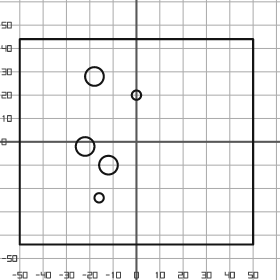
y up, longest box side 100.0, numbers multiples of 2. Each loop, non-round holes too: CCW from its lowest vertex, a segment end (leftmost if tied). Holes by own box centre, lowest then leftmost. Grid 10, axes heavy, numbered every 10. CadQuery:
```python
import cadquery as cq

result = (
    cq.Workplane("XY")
    .moveTo(-50.0, -44.0)
    .lineTo(50.0, -44.0)
    .lineTo(50.0, 44.0)
    .lineTo(-50.0, 44.0)
    .close()
    .moveTo(-16.0, -24.0)
    .circle(2.0)
    .moveTo(-12.0, -10.0)
    .circle(4.0)
    .moveTo(-22.0, -2.0)
    .circle(4.0)
    .moveTo(0.0, 20.0)
    .circle(2.0)
    .moveTo(-18.0, 28.0)
    .circle(4.0)
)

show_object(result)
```